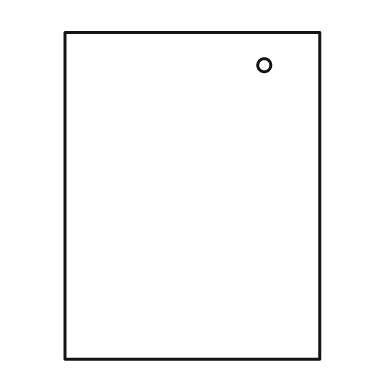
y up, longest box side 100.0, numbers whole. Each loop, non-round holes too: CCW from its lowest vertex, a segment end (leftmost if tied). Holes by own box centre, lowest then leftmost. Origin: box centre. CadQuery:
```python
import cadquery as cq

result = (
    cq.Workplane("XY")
    .moveTo(-39.0, -50.0)
    .lineTo(39.0, -50.0)
    .lineTo(39.0, 50.0)
    .lineTo(-39.0, 50.0)
    .close()
    .moveTo(22.0, 40.0)
    .circle(2.0)
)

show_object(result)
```